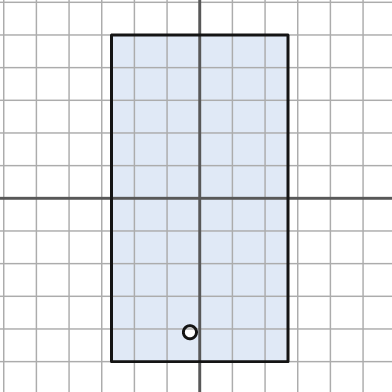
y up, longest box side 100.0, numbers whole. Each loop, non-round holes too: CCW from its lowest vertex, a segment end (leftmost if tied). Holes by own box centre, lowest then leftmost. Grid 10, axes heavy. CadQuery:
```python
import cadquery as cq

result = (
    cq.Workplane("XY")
    .moveTo(-27.0, -50.0)
    .lineTo(27.0, -50.0)
    .lineTo(27.0, 50.0)
    .lineTo(-27.0, 50.0)
    .close()
    .moveTo(-3.0, -41.0)
    .circle(2.0)
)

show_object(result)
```